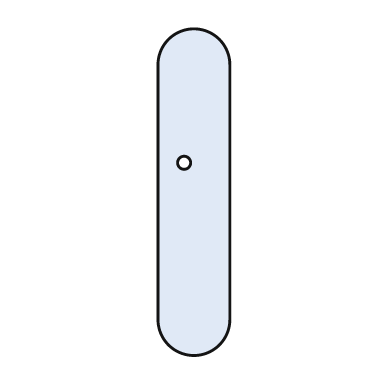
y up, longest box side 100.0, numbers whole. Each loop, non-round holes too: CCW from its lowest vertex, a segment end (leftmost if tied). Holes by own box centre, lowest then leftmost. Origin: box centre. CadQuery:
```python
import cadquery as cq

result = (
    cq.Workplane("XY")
    .moveTo(-11.0, -39.0)
    .threePointArc((0.0, -50.0), (11.0, -39.0))
    .lineTo(11.0, 39.0)
    .threePointArc((0.0, 50.0), (-11.0, 39.0))
    .close()
    .moveTo(-3.0, 9.0)
    .circle(2.0)
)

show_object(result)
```